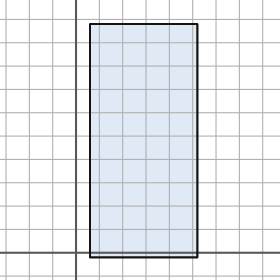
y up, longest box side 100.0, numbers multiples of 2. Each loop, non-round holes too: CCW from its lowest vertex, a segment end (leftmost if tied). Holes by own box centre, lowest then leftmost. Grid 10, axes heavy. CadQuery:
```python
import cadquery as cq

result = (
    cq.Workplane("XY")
    .moveTo(6.0, -2.0)
    .lineTo(52.0, -2.0)
    .lineTo(52.0, 98.0)
    .lineTo(6.0, 98.0)
    .close()
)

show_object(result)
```